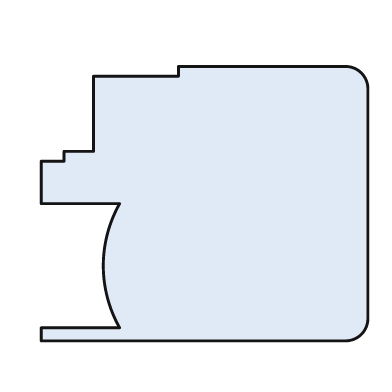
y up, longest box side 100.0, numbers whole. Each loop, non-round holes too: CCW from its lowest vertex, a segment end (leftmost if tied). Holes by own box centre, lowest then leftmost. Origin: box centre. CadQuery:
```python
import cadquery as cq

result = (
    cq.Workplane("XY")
    .moveTo(-50.0, -42.0)
    .lineTo(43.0, -42.0)
    .threePointArc((48.0, -40.0), (50.0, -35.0))
    .lineTo(50.0, 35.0)
    .threePointArc((48.0, 40.0), (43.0, 42.0))
    .lineTo(-8.0, 42.0)
    .lineTo(-8.0, 39.0)
    .lineTo(-34.0, 39.0)
    .lineTo(-34.0, 16.0)
    .lineTo(-43.0, 16.0)
    .lineTo(-43.0, 13.0)
    .lineTo(-50.0, 13.0)
    .lineTo(-50.0, 0.0)
    .lineTo(-26.0, 0.0)
    .threePointArc((-31.0, -19.0), (-26.0, -38.0))
    .lineTo(-50.0, -38.0)
    .close()
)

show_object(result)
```